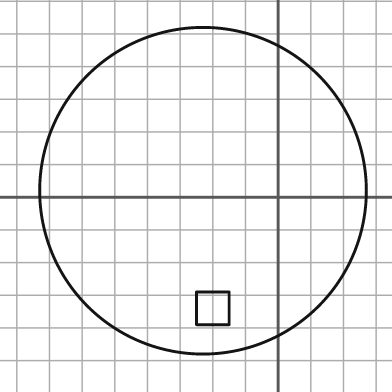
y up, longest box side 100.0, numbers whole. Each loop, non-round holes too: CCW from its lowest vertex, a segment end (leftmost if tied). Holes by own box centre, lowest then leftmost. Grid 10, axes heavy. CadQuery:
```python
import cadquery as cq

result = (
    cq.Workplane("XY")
    .moveTo(-23.0, 2.0)
    .circle(50.0)
    .moveTo(-25.0, -39.0)
    .lineTo(-15.0, -39.0)
    .lineTo(-15.0, -29.0)
    .lineTo(-25.0, -29.0)
    .close()
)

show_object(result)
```